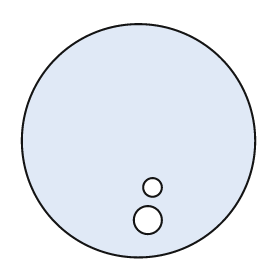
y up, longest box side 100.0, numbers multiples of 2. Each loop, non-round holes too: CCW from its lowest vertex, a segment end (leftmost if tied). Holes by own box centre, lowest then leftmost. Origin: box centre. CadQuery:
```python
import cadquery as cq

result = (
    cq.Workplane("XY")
    .moveTo(0.0, 0.0)
    .circle(50.0)
    .moveTo(4.0, -34.0)
    .circle(6.0)
    .moveTo(6.0, -20.0)
    .circle(4.0)
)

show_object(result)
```